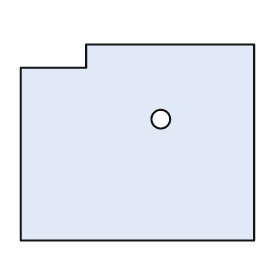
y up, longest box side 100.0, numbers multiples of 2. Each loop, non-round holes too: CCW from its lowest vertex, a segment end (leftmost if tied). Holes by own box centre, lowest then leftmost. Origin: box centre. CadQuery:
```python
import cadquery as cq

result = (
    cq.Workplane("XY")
    .moveTo(-50.0, -42.0)
    .lineTo(50.0, -42.0)
    .lineTo(50.0, 42.0)
    .lineTo(-22.0, 42.0)
    .lineTo(-22.0, 32.0)
    .lineTo(-50.0, 32.0)
    .close()
    .moveTo(10.0, 10.0)
    .circle(4.0)
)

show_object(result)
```